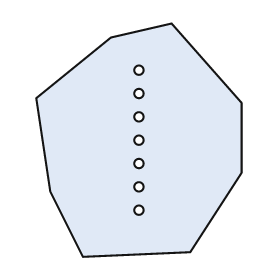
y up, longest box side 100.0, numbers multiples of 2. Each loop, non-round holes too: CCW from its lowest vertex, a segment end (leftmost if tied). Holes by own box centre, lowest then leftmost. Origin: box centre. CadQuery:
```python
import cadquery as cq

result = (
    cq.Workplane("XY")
    .moveTo(-24.0, -50.0)
    .lineTo(22.0, -48.0)
    .lineTo(44.0, -14.0)
    .lineTo(44.0, 16.0)
    .lineTo(14.0, 50.0)
    .lineTo(-12.0, 44.0)
    .lineTo(-44.0, 18.0)
    .lineTo(-38.0, -22.0)
    .close()
    .moveTo(0.0, -30.0)
    .circle(2.0)
    .moveTo(0.0, -20.0)
    .circle(2.0)
    .moveTo(0.0, -10.0)
    .circle(2.0)
    .moveTo(0.0, 0.0)
    .circle(2.0)
    .moveTo(0.0, 10.0)
    .circle(2.0)
    .moveTo(0.0, 20.0)
    .circle(2.0)
    .moveTo(0.0, 30.0)
    .circle(2.0)
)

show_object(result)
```